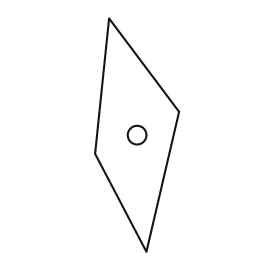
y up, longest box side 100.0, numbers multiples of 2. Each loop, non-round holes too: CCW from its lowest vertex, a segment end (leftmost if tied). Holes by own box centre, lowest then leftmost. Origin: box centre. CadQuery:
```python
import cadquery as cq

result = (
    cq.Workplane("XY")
    .moveTo(4.0, -50.0)
    .lineTo(18.0, 10.0)
    .lineTo(-12.0, 50.0)
    .lineTo(-18.0, -8.0)
    .close()
    .moveTo(0.0, 0.0)
    .circle(4.0)
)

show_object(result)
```